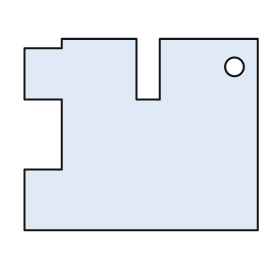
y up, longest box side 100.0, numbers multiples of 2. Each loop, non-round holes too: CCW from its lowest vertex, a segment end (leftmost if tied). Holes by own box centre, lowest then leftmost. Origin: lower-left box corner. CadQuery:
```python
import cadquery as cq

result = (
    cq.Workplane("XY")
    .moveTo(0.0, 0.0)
    .lineTo(100.0, 0.0)
    .lineTo(100.0, 82.0)
    .lineTo(58.0, 82.0)
    .lineTo(58.0, 56.0)
    .lineTo(48.0, 56.0)
    .lineTo(48.0, 82.0)
    .lineTo(16.0, 82.0)
    .lineTo(16.0, 78.0)
    .lineTo(0.0, 78.0)
    .lineTo(0.0, 56.0)
    .lineTo(16.0, 56.0)
    .lineTo(16.0, 26.0)
    .lineTo(0.0, 26.0)
    .close()
    .moveTo(90.0, 70.0)
    .circle(4.0)
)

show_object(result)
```